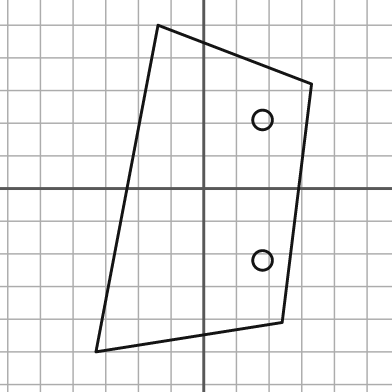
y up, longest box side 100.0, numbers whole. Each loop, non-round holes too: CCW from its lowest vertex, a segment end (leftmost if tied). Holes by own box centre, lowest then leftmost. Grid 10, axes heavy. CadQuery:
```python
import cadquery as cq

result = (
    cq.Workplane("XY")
    .moveTo(-33.0, -50.0)
    .lineTo(24.0, -41.0)
    .lineTo(33.0, 32.0)
    .lineTo(-14.0, 50.0)
    .close()
    .moveTo(18.0, -22.0)
    .circle(3.0)
    .moveTo(18.0, 21.0)
    .circle(3.0)
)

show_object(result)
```